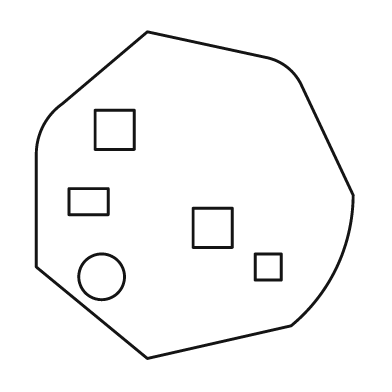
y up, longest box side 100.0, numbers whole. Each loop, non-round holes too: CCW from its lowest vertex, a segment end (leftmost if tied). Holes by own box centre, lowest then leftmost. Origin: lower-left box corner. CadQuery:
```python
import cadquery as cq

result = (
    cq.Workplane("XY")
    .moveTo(34.0, 0.0)
    .lineTo(78.0, 10.0)
    .threePointArc((92.0, 28.0), (97.0, 50.0))
    .lineTo(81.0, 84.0)
    .threePointArc((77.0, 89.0), (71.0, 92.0))
    .lineTo(34.0, 100.0)
    .lineTo(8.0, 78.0)
    .threePointArc((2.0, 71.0), (0.0, 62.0))
    .lineTo(0.0, 28.0)
    .close()
    .moveTo(20.0, 25.0)
    .circle(7.0)
    .moveTo(67.0, 24.0)
    .lineTo(75.0, 24.0)
    .lineTo(75.0, 32.0)
    .lineTo(67.0, 32.0)
    .close()
    .moveTo(48.0, 34.0)
    .lineTo(60.0, 34.0)
    .lineTo(60.0, 46.0)
    .lineTo(48.0, 46.0)
    .close()
    .moveTo(10.0, 44.0)
    .lineTo(22.0, 44.0)
    .lineTo(22.0, 52.0)
    .lineTo(10.0, 52.0)
    .close()
    .moveTo(18.0, 64.0)
    .lineTo(30.0, 64.0)
    .lineTo(30.0, 76.0)
    .lineTo(18.0, 76.0)
    .close()
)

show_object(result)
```